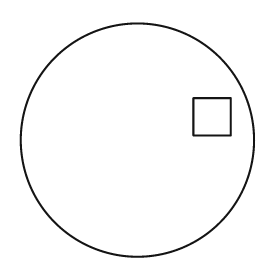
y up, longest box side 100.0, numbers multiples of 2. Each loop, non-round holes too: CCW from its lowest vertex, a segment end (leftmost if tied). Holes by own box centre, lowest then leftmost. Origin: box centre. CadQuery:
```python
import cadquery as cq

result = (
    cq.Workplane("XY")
    .moveTo(0.0, 0.0)
    .circle(50.0)
    .moveTo(24.0, 2.0)
    .lineTo(40.0, 2.0)
    .lineTo(40.0, 18.0)
    .lineTo(24.0, 18.0)
    .close()
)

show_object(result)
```